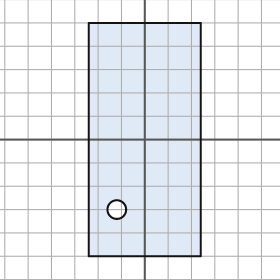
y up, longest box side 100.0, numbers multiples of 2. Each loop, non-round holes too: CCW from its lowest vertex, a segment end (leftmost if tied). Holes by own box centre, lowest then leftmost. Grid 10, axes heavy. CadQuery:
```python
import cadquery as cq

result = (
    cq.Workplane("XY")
    .moveTo(-24.0, -50.0)
    .lineTo(24.0, -50.0)
    .lineTo(24.0, 50.0)
    .lineTo(-24.0, 50.0)
    .close()
    .moveTo(-12.0, -30.0)
    .circle(4.0)
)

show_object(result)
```